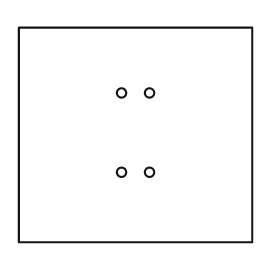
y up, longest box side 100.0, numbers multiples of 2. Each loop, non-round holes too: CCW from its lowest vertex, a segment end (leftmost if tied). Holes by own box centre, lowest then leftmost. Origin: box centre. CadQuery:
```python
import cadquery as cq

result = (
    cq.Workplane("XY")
    .moveTo(-50.0, -46.0)
    .lineTo(50.0, -46.0)
    .lineTo(50.0, 46.0)
    .lineTo(-50.0, 46.0)
    .close()
    .moveTo(-6.0, -16.0)
    .circle(2.0)
    .moveTo(6.0, -16.0)
    .circle(2.0)
    .moveTo(-6.0, 18.0)
    .circle(2.0)
    .moveTo(6.0, 18.0)
    .circle(2.0)
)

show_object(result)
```